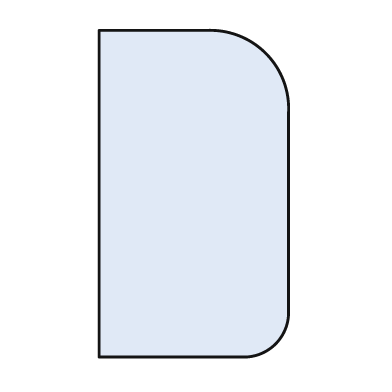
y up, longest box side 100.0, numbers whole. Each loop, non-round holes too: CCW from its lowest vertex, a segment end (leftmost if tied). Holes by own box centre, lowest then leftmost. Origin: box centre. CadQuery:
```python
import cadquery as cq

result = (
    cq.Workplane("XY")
    .moveTo(-29.0, -50.0)
    .lineTo(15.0, -50.0)
    .threePointArc((25.0, -46.0), (29.0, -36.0))
    .lineTo(29.0, 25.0)
    .threePointArc((22.0, 43.0), (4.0, 50.0))
    .lineTo(-29.0, 50.0)
    .close()
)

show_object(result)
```